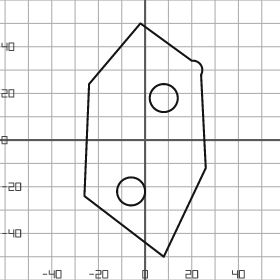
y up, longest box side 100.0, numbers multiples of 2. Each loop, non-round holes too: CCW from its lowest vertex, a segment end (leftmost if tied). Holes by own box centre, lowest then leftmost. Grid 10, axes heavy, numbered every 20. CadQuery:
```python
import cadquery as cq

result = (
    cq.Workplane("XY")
    .moveTo(8.0, -50.0)
    .lineTo(26.0, -12.0)
    .lineTo(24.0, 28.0)
    .threePointArc((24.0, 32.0), (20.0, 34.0))
    .lineTo(-2.0, 50.0)
    .lineTo(-24.0, 24.0)
    .lineTo(-26.0, -24.0)
    .close()
    .moveTo(-6.0, -22.0)
    .circle(6.0)
    .moveTo(8.0, 18.0)
    .circle(6.0)
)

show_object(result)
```